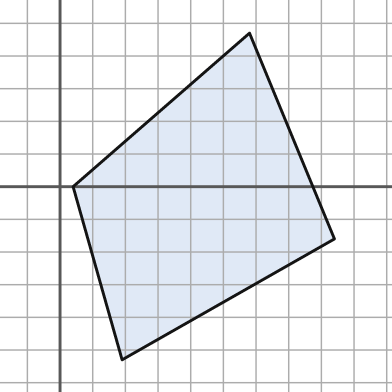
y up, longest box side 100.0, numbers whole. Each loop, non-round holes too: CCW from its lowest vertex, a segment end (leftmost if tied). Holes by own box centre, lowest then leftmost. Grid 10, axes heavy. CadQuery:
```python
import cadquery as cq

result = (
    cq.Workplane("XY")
    .moveTo(19.0, -53.0)
    .lineTo(84.0, -16.0)
    .lineTo(58.0, 47.0)
    .lineTo(4.0, 0.0)
    .close()
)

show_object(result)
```